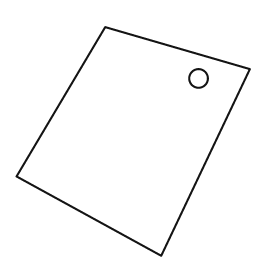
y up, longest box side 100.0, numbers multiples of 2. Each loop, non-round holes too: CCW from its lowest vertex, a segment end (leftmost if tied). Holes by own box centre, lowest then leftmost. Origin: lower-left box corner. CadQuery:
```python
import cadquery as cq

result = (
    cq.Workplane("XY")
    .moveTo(62.0, 0.0)
    .lineTo(100.0, 80.0)
    .lineTo(38.0, 98.0)
    .lineTo(0.0, 34.0)
    .close()
    .moveTo(78.0, 76.0)
    .circle(4.0)
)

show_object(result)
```